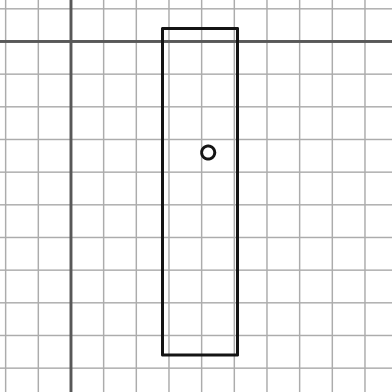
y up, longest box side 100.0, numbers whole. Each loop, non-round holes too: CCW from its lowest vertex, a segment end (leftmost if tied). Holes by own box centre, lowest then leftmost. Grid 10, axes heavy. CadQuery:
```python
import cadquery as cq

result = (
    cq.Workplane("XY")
    .moveTo(28.0, -96.0)
    .lineTo(51.0, -96.0)
    .lineTo(51.0, 4.0)
    .lineTo(28.0, 4.0)
    .close()
    .moveTo(42.0, -34.0)
    .circle(2.0)
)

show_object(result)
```